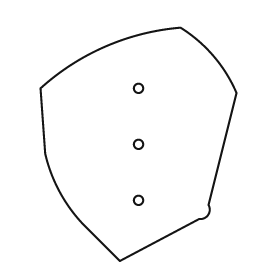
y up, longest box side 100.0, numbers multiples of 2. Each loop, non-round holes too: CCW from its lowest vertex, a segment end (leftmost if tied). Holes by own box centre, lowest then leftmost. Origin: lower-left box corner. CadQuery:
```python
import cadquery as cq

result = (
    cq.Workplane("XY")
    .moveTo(34.0, 0.0)
    .lineTo(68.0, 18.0)
    .threePointArc((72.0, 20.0), (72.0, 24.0))
    .lineTo(84.0, 72.0)
    .threePointArc((74.0, 88.0), (60.0, 100.0))
    .threePointArc((28.0, 92.0), (0.0, 74.0))
    .lineTo(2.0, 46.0)
    .threePointArc((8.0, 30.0), (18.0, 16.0))
    .close()
    .moveTo(42.0, 26.0)
    .circle(2.0)
    .moveTo(42.0, 50.0)
    .circle(2.0)
    .moveTo(42.0, 74.0)
    .circle(2.0)
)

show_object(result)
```